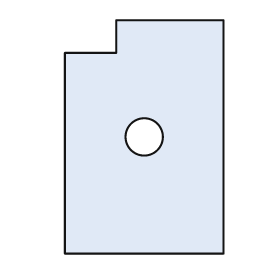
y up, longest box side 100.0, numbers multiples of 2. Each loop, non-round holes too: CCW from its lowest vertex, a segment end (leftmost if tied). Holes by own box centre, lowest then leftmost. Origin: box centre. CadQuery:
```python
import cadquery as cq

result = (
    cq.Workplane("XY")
    .moveTo(-34.0, -50.0)
    .lineTo(34.0, -50.0)
    .lineTo(34.0, 50.0)
    .lineTo(-12.0, 50.0)
    .lineTo(-12.0, 36.0)
    .lineTo(-34.0, 36.0)
    .close()
    .moveTo(0.0, 0.0)
    .circle(8.0)
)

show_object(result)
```